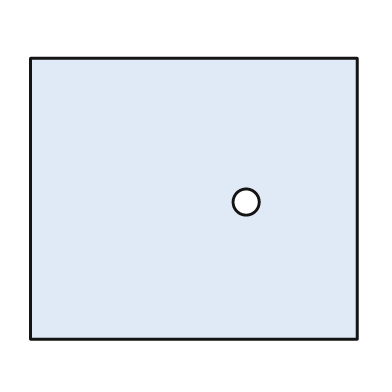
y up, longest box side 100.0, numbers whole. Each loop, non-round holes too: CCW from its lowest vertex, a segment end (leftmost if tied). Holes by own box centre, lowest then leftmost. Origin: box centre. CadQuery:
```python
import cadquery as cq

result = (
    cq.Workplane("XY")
    .moveTo(-50.0, -43.0)
    .lineTo(50.0, -43.0)
    .lineTo(50.0, 43.0)
    .lineTo(-50.0, 43.0)
    .close()
    .moveTo(16.0, -1.0)
    .circle(4.0)
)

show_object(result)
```